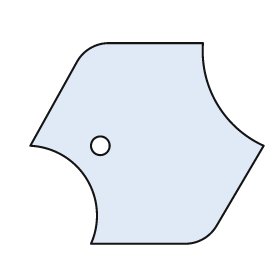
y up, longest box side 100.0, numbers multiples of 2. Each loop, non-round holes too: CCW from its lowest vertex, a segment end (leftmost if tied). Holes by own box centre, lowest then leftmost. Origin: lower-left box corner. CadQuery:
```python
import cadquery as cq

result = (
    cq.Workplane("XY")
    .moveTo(26.0, 0.0)
    .lineTo(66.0, 0.0)
    .threePointArc((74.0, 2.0), (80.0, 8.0))
    .lineTo(100.0, 42.0)
    .threePointArc((80.0, 60.0), (74.0, 86.0))
    .lineTo(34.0, 86.0)
    .threePointArc((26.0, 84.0), (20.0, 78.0))
    .lineTo(0.0, 42.0)
    .threePointArc((24.0, 28.0), (26.0, 0.0))
    .close()
    .moveTo(30.0, 42.0)
    .circle(4.0)
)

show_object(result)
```